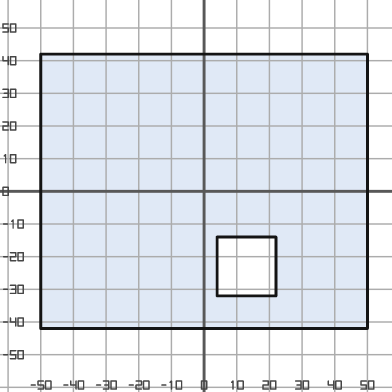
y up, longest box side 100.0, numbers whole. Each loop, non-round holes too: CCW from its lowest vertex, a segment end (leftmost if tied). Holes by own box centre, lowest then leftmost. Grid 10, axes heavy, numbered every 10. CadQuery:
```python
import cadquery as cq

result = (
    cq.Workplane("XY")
    .moveTo(-50.0, -42.0)
    .lineTo(50.0, -42.0)
    .lineTo(50.0, 42.0)
    .lineTo(-50.0, 42.0)
    .close()
    .moveTo(4.0, -32.0)
    .lineTo(22.0, -32.0)
    .lineTo(22.0, -14.0)
    .lineTo(4.0, -14.0)
    .close()
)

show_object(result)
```